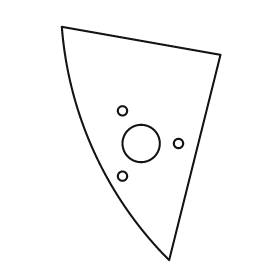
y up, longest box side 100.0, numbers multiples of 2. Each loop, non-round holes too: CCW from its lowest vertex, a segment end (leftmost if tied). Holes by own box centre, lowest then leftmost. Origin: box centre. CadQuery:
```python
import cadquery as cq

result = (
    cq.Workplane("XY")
    .moveTo(12.0, -50.0)
    .lineTo(34.0, 38.0)
    .lineTo(-34.0, 50.0)
    .threePointArc((-20.0, -4.0), (12.0, -50.0))
    .close()
    .moveTo(-8.0, -14.0)
    .circle(2.0)
    .moveTo(0.0, 0.0)
    .circle(8.0)
    .moveTo(16.0, 0.0)
    .circle(2.0)
    .moveTo(-8.0, 14.0)
    .circle(2.0)
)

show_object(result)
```